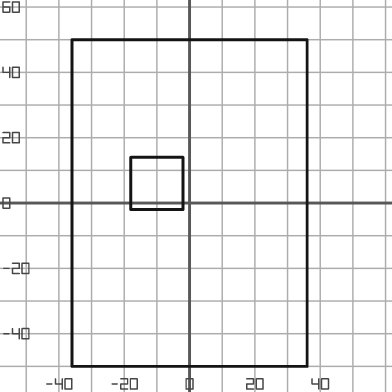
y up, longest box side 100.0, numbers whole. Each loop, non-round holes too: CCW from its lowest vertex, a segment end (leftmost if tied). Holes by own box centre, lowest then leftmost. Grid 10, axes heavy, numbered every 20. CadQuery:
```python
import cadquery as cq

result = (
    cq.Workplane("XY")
    .moveTo(-36.0, -50.0)
    .lineTo(36.0, -50.0)
    .lineTo(36.0, 50.0)
    .lineTo(-36.0, 50.0)
    .close()
    .moveTo(-18.0, -2.0)
    .lineTo(-2.0, -2.0)
    .lineTo(-2.0, 14.0)
    .lineTo(-18.0, 14.0)
    .close()
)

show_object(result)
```